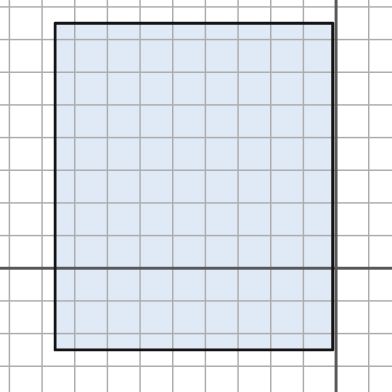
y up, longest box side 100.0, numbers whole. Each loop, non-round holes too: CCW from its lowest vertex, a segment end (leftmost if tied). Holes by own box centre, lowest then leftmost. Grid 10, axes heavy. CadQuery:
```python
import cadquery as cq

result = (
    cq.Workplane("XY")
    .moveTo(-86.0, -25.0)
    .lineTo(-1.0, -25.0)
    .lineTo(-1.0, 75.0)
    .lineTo(-86.0, 75.0)
    .close()
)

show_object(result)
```